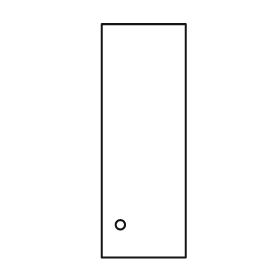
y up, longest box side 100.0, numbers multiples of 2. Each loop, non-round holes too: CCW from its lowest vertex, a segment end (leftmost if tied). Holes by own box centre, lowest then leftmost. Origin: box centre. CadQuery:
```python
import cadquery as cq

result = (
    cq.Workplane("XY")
    .moveTo(-18.0, -50.0)
    .lineTo(18.0, -50.0)
    .lineTo(18.0, 50.0)
    .lineTo(-18.0, 50.0)
    .close()
    .moveTo(-10.0, -36.0)
    .circle(2.0)
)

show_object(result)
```